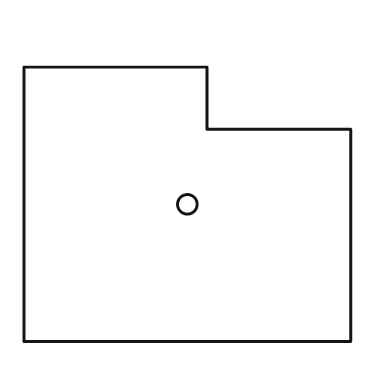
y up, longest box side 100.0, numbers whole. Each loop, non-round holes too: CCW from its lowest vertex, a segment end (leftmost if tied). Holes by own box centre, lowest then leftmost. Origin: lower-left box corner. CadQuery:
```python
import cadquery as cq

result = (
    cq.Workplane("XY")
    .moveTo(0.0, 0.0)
    .lineTo(100.0, 0.0)
    .lineTo(100.0, 65.0)
    .lineTo(56.0, 65.0)
    .lineTo(56.0, 84.0)
    .lineTo(0.0, 84.0)
    .close()
    .moveTo(50.0, 42.0)
    .circle(3.0)
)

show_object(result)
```